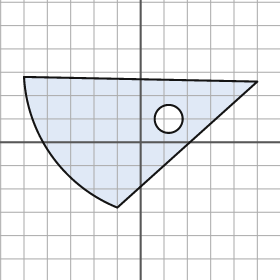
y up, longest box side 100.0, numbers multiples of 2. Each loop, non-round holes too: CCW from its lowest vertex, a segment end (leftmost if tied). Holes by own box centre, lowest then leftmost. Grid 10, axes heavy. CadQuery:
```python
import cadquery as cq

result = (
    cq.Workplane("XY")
    .moveTo(-10.0, -28.0)
    .lineTo(50.0, 26.0)
    .lineTo(-50.0, 28.0)
    .threePointArc((-38.0, -6.0), (-10.0, -28.0))
    .close()
    .moveTo(12.0, 10.0)
    .circle(6.0)
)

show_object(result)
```